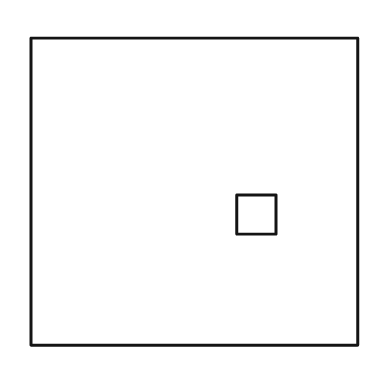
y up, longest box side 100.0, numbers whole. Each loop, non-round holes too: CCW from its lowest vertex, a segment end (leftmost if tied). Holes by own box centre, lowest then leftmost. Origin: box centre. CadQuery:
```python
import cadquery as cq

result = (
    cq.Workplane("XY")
    .moveTo(-50.0, -47.0)
    .lineTo(50.0, -47.0)
    .lineTo(50.0, 47.0)
    .lineTo(-50.0, 47.0)
    .close()
    .moveTo(13.0, -13.0)
    .lineTo(25.0, -13.0)
    .lineTo(25.0, -1.0)
    .lineTo(13.0, -1.0)
    .close()
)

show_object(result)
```